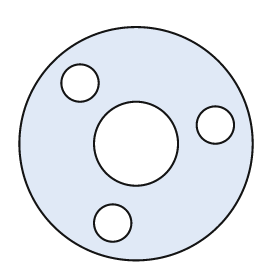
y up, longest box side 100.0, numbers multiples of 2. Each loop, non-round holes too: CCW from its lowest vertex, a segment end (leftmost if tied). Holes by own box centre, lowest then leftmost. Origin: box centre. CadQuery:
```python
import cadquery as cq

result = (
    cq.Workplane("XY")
    .moveTo(0.0, 0.0)
    .circle(50.0)
    .moveTo(-10.0, -34.0)
    .circle(8.0)
    .moveTo(0.0, 0.0)
    .circle(18.0)
    .moveTo(34.0, 8.0)
    .circle(8.0)
    .moveTo(-24.0, 26.0)
    .circle(8.0)
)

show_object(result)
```